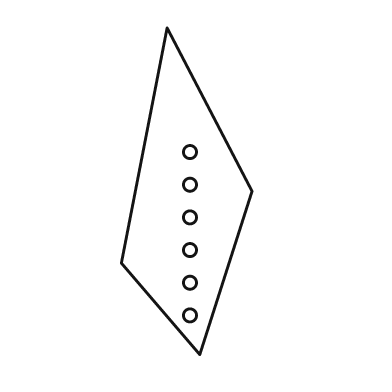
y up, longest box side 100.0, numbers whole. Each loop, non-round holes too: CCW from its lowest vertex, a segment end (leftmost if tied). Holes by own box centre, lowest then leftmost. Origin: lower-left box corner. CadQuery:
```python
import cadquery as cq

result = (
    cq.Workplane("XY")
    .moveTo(24.0, 0.0)
    .lineTo(40.0, 50.0)
    .lineTo(14.0, 100.0)
    .lineTo(0.0, 28.0)
    .close()
    .moveTo(21.0, 12.0)
    .circle(2.0)
    .moveTo(21.0, 22.0)
    .circle(2.0)
    .moveTo(21.0, 32.0)
    .circle(2.0)
    .moveTo(21.0, 42.0)
    .circle(2.0)
    .moveTo(21.0, 52.0)
    .circle(2.0)
    .moveTo(21.0, 62.0)
    .circle(2.0)
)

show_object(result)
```